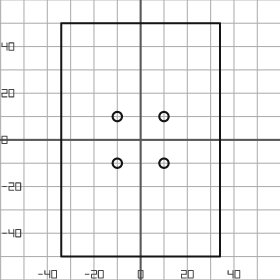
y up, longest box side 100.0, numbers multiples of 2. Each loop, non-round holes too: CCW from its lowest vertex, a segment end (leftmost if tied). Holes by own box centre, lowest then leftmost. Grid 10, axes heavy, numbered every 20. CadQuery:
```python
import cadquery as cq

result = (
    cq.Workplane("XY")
    .moveTo(-34.0, -50.0)
    .lineTo(34.0, -50.0)
    .lineTo(34.0, 50.0)
    .lineTo(-34.0, 50.0)
    .close()
    .moveTo(-10.0, -10.0)
    .circle(2.0)
    .moveTo(10.0, -10.0)
    .circle(2.0)
    .moveTo(-10.0, 10.0)
    .circle(2.0)
    .moveTo(10.0, 10.0)
    .circle(2.0)
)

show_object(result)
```